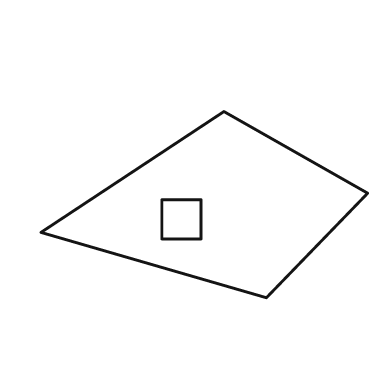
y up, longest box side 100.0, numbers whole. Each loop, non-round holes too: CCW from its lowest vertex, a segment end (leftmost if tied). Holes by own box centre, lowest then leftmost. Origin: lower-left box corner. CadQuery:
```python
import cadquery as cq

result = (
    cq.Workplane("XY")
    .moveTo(69.0, 0.0)
    .lineTo(100.0, 32.0)
    .lineTo(56.0, 57.0)
    .lineTo(0.0, 20.0)
    .close()
    .moveTo(37.0, 18.0)
    .lineTo(49.0, 18.0)
    .lineTo(49.0, 30.0)
    .lineTo(37.0, 30.0)
    .close()
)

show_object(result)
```